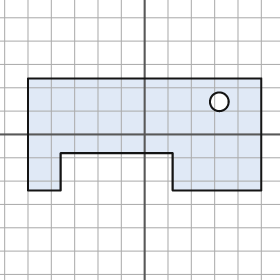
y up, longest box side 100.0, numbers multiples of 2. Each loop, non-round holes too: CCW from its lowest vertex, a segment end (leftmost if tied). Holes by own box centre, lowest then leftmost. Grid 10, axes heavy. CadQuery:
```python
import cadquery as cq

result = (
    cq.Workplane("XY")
    .moveTo(-50.0, -24.0)
    .lineTo(-36.0, -24.0)
    .lineTo(-36.0, -8.0)
    .lineTo(12.0, -8.0)
    .lineTo(12.0, -24.0)
    .lineTo(50.0, -24.0)
    .lineTo(50.0, 24.0)
    .lineTo(-50.0, 24.0)
    .close()
    .moveTo(32.0, 14.0)
    .circle(4.0)
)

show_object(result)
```